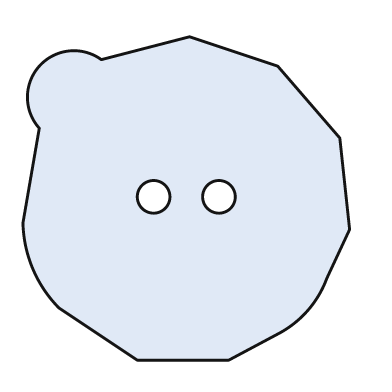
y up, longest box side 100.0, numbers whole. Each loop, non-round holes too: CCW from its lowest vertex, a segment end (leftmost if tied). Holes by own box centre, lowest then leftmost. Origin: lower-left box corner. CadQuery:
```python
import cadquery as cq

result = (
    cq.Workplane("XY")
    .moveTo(35.0, 0.0)
    .lineTo(63.0, 0.0)
    .lineTo(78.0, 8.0)
    .threePointArc((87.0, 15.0), (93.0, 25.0))
    .lineTo(100.0, 40.0)
    .lineTo(97.0, 68.0)
    .lineTo(78.0, 90.0)
    .lineTo(51.0, 99.0)
    .lineTo(24.0, 92.0)
    .threePointArc((5.0, 90.0), (5.0, 71.0))
    .lineTo(0.0, 42.0)
    .threePointArc((3.0, 28.0), (11.0, 16.0))
    .close()
    .moveTo(40.0, 50.0)
    .circle(5.0)
    .moveTo(60.0, 50.0)
    .circle(5.0)
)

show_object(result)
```